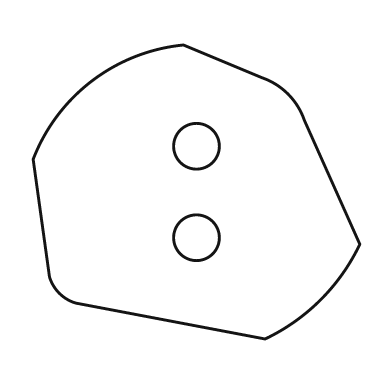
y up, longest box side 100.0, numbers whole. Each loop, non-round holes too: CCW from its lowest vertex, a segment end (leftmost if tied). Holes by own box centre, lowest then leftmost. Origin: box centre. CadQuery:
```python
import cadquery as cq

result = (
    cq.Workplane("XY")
    .moveTo(21.0, -45.0)
    .threePointArc((38.0, -33.0), (50.0, -16.0))
    .lineTo(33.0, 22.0)
    .threePointArc((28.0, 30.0), (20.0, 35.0))
    .lineTo(-4.0, 45.0)
    .threePointArc((-32.0, 34.0), (-50.0, 10.0))
    .lineTo(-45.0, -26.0)
    .threePointArc((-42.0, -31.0), (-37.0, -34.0))
    .close()
    .moveTo(0.0, -14.0)
    .circle(7.0)
    .moveTo(0.0, 14.0)
    .circle(7.0)
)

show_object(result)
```